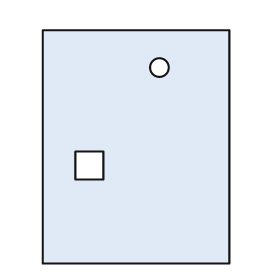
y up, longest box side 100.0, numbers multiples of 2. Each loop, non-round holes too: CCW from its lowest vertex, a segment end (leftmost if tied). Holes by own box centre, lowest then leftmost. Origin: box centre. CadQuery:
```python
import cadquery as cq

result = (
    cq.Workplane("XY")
    .moveTo(-40.0, -50.0)
    .lineTo(40.0, -50.0)
    .lineTo(40.0, 50.0)
    .lineTo(-40.0, 50.0)
    .close()
    .moveTo(-26.0, -14.0)
    .lineTo(-14.0, -14.0)
    .lineTo(-14.0, -2.0)
    .lineTo(-26.0, -2.0)
    .close()
    .moveTo(10.0, 34.0)
    .circle(4.0)
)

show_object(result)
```